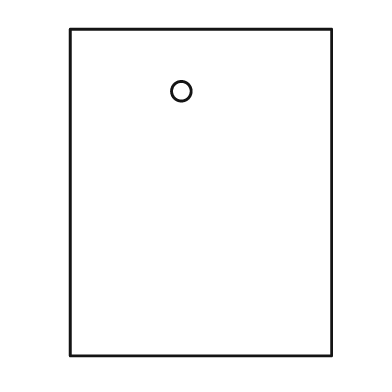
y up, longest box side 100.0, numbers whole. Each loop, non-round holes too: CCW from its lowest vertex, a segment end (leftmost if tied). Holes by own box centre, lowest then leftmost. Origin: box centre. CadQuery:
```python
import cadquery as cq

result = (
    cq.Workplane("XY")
    .moveTo(-40.0, -50.0)
    .lineTo(40.0, -50.0)
    .lineTo(40.0, 50.0)
    .lineTo(-40.0, 50.0)
    .close()
    .moveTo(-6.0, 31.0)
    .circle(3.0)
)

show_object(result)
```